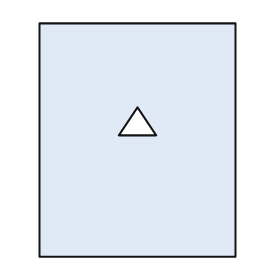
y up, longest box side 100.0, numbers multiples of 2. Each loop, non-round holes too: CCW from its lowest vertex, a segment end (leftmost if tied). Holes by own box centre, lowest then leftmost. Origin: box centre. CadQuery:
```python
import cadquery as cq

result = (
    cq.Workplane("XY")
    .moveTo(-42.0, -50.0)
    .lineTo(42.0, -50.0)
    .lineTo(42.0, 50.0)
    .lineTo(-42.0, 50.0)
    .close()
    .moveTo(-8.0, 2.0)
    .lineTo(8.0, 2.0)
    .lineTo(0.0, 14.0)
    .close()
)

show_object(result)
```